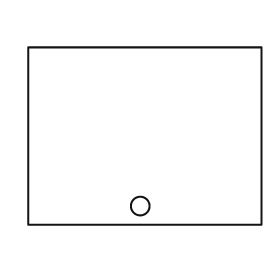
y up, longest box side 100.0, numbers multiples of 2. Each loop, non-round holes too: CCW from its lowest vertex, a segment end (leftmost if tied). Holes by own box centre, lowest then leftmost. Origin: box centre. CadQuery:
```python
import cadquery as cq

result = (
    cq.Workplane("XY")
    .moveTo(-50.0, -38.0)
    .lineTo(50.0, -38.0)
    .lineTo(50.0, 38.0)
    .lineTo(-50.0, 38.0)
    .close()
    .moveTo(-2.0, -30.0)
    .circle(4.0)
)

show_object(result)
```